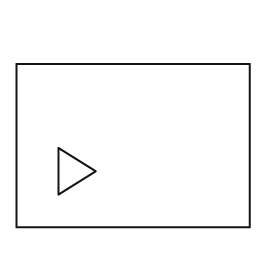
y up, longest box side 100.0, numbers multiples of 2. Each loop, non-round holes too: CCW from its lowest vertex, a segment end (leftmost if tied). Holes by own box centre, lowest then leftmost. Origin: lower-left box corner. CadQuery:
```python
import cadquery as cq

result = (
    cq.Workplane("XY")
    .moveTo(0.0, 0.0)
    .lineTo(100.0, 0.0)
    .lineTo(100.0, 70.0)
    .lineTo(0.0, 70.0)
    .close()
    .moveTo(18.0, 14.0)
    .lineTo(34.0, 24.0)
    .lineTo(18.0, 34.0)
    .close()
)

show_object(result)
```